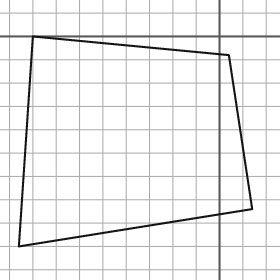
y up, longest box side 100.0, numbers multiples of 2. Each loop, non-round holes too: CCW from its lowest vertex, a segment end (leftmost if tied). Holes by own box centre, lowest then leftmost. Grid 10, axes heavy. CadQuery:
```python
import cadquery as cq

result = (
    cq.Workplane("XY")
    .moveTo(-86.0, -90.0)
    .lineTo(14.0, -74.0)
    .lineTo(4.0, -8.0)
    .lineTo(-80.0, 0.0)
    .close()
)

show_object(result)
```